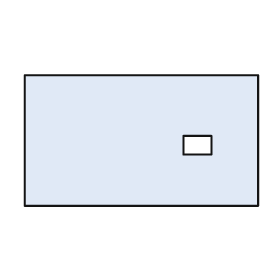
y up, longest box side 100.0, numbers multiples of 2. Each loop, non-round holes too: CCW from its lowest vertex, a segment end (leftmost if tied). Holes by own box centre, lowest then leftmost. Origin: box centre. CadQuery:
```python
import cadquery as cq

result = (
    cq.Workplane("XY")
    .moveTo(-50.0, -28.0)
    .lineTo(50.0, -28.0)
    .lineTo(50.0, 28.0)
    .lineTo(-50.0, 28.0)
    .close()
    .moveTo(18.0, -6.0)
    .lineTo(30.0, -6.0)
    .lineTo(30.0, 2.0)
    .lineTo(18.0, 2.0)
    .close()
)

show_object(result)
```